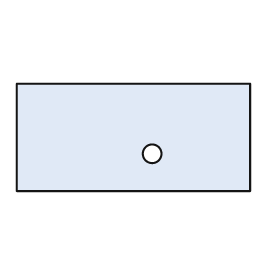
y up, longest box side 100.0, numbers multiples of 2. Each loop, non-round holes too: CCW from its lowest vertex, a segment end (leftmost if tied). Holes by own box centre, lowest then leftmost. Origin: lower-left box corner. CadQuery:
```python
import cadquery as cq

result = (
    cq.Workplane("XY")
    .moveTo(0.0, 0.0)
    .lineTo(100.0, 0.0)
    .lineTo(100.0, 46.0)
    .lineTo(0.0, 46.0)
    .close()
    .moveTo(58.0, 16.0)
    .circle(4.0)
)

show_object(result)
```